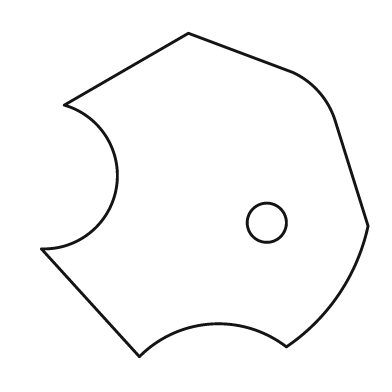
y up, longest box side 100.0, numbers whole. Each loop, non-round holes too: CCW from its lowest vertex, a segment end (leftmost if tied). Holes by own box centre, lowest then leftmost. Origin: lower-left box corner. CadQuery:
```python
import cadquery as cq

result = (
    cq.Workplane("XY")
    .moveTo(30.0, 0.0)
    .threePointArc((52.0, 10.0), (75.0, 3.0))
    .threePointArc((91.0, 19.0), (100.0, 40.0))
    .lineTo(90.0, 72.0)
    .threePointArc((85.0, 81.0), (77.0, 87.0))
    .lineTo(45.0, 99.0)
    .lineTo(7.0, 77.0)
    .threePointArc((23.0, 52.0), (0.0, 33.0))
    .close()
    .moveTo(69.0, 41.0)
    .circle(6.0)
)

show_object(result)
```